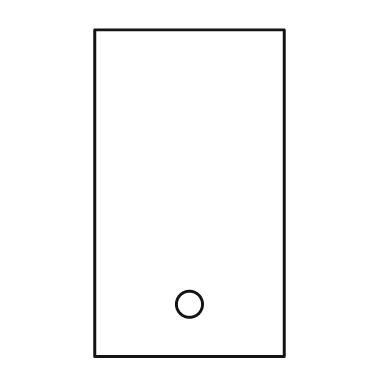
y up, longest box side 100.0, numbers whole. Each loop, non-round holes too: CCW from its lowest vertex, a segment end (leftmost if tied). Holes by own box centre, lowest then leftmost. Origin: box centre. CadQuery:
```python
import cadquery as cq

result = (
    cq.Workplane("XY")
    .moveTo(-29.0, -50.0)
    .lineTo(29.0, -50.0)
    .lineTo(29.0, 50.0)
    .lineTo(-29.0, 50.0)
    .close()
    .moveTo(0.0, -34.0)
    .circle(4.0)
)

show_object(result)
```